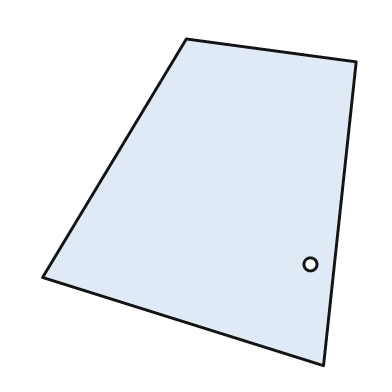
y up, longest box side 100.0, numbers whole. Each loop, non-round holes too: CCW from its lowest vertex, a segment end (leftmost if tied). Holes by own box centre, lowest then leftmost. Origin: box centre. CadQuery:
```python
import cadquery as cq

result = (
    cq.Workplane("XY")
    .moveTo(38.0, -50.0)
    .lineTo(48.0, 43.0)
    .lineTo(-4.0, 50.0)
    .lineTo(-48.0, -23.0)
    .close()
    .moveTo(34.0, -19.0)
    .circle(2.0)
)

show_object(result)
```